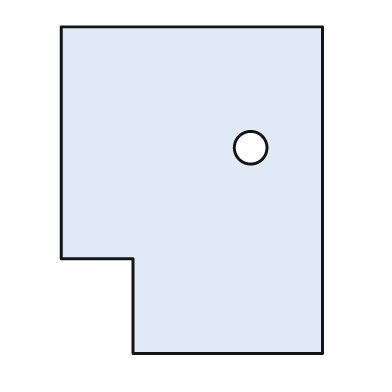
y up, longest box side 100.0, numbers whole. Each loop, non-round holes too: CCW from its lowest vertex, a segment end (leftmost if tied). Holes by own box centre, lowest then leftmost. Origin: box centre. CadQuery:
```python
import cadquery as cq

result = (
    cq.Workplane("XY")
    .moveTo(-18.0, -50.0)
    .lineTo(40.0, -50.0)
    .lineTo(40.0, 50.0)
    .lineTo(-40.0, 50.0)
    .lineTo(-40.0, -21.0)
    .lineTo(-18.0, -21.0)
    .close()
    .moveTo(18.0, 13.0)
    .circle(5.0)
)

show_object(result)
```